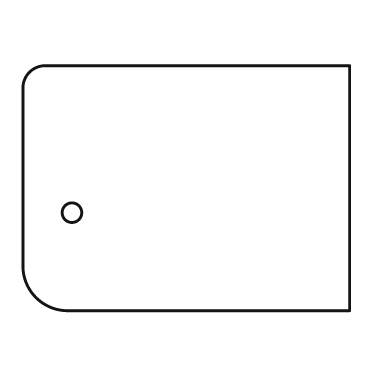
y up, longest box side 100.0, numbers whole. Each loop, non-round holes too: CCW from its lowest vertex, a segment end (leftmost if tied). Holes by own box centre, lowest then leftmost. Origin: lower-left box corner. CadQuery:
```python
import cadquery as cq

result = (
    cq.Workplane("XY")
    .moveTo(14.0, 0.0)
    .lineTo(100.0, 0.0)
    .lineTo(100.0, 75.0)
    .lineTo(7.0, 75.0)
    .threePointArc((2.0, 73.0), (0.0, 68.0))
    .lineTo(0.0, 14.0)
    .threePointArc((4.0, 4.0), (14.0, 0.0))
    .close()
    .moveTo(15.0, 30.0)
    .circle(3.0)
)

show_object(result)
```